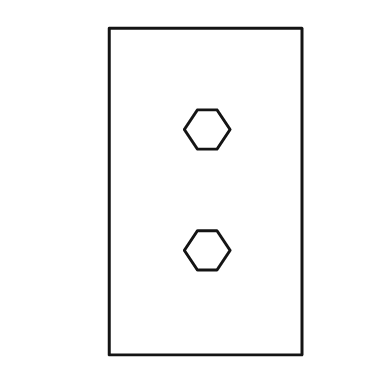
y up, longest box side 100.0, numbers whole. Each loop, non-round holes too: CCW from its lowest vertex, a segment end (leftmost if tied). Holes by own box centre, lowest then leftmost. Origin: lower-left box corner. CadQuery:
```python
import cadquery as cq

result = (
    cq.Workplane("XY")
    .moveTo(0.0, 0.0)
    .lineTo(59.0, 0.0)
    .lineTo(59.0, 100.0)
    .lineTo(0.0, 100.0)
    .close()
    .moveTo(27.0, 26.0)
    .lineTo(33.0, 26.0)
    .lineTo(37.0, 32.0)
    .lineTo(33.0, 38.0)
    .lineTo(27.0, 38.0)
    .lineTo(23.0, 32.0)
    .close()
    .moveTo(27.0, 63.0)
    .lineTo(33.0, 63.0)
    .lineTo(37.0, 69.0)
    .lineTo(33.0, 75.0)
    .lineTo(27.0, 75.0)
    .lineTo(23.0, 69.0)
    .close()
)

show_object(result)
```